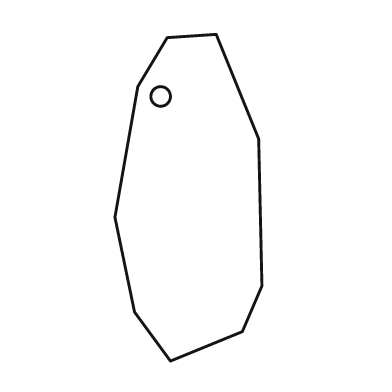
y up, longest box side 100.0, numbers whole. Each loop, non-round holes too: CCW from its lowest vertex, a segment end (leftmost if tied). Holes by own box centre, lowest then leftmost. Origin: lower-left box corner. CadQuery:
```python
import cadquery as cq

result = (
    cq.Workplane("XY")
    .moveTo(17.0, 0.0)
    .lineTo(39.0, 9.0)
    .lineTo(45.0, 23.0)
    .lineTo(44.0, 68.0)
    .lineTo(31.0, 100.0)
    .lineTo(16.0, 99.0)
    .lineTo(7.0, 84.0)
    .lineTo(0.0, 44.0)
    .lineTo(6.0, 15.0)
    .close()
    .moveTo(14.0, 81.0)
    .circle(3.0)
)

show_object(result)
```